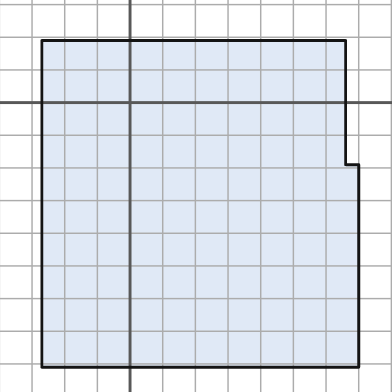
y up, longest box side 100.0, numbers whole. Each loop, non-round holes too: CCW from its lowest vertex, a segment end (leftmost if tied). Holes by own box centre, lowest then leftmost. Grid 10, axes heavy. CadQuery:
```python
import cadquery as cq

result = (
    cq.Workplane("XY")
    .moveTo(-27.0, -81.0)
    .lineTo(70.0, -81.0)
    .lineTo(70.0, -19.0)
    .lineTo(66.0, -19.0)
    .lineTo(66.0, 19.0)
    .lineTo(-27.0, 19.0)
    .close()
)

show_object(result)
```